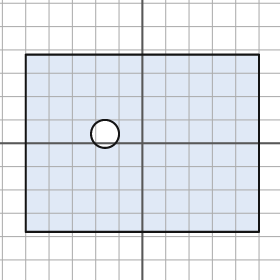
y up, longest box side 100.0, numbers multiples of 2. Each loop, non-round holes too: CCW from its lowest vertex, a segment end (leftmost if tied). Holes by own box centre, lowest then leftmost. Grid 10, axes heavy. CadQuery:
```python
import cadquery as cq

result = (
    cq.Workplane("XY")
    .moveTo(-50.0, -38.0)
    .lineTo(50.0, -38.0)
    .lineTo(50.0, 38.0)
    .lineTo(-50.0, 38.0)
    .close()
    .moveTo(-16.0, 4.0)
    .circle(6.0)
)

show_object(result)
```